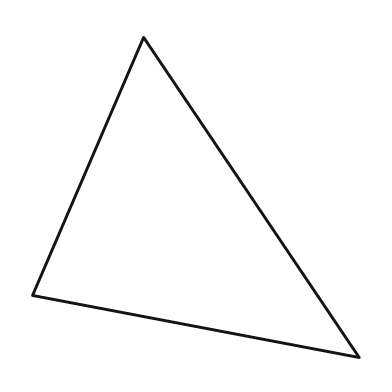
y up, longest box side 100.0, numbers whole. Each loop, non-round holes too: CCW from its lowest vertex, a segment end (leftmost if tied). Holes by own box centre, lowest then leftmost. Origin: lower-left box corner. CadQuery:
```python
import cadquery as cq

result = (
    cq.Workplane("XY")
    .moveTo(100.0, 0.0)
    .lineTo(34.0, 98.0)
    .lineTo(0.0, 19.0)
    .close()
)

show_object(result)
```